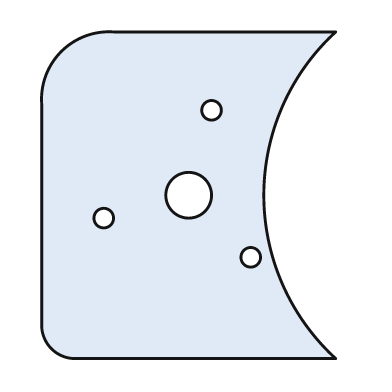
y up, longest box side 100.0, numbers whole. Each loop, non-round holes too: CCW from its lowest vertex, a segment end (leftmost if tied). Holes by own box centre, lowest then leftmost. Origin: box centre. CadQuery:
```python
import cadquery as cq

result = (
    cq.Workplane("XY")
    .moveTo(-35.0, -50.0)
    .lineTo(45.0, -50.0)
    .threePointArc((23.0, 0.0), (45.0, 50.0))
    .lineTo(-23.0, 50.0)
    .threePointArc((-39.0, 44.0), (-45.0, 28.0))
    .lineTo(-45.0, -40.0)
    .threePointArc((-42.0, -47.0), (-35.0, -50.0))
    .close()
    .moveTo(19.0, -19.0)
    .circle(3.0)
    .moveTo(-26.0, -7.0)
    .circle(3.0)
    .moveTo(0.0, 0.0)
    .circle(7.0)
    .moveTo(7.0, 26.0)
    .circle(3.0)
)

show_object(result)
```